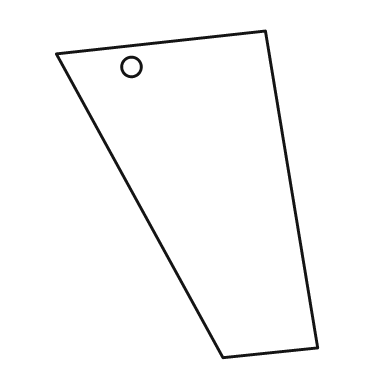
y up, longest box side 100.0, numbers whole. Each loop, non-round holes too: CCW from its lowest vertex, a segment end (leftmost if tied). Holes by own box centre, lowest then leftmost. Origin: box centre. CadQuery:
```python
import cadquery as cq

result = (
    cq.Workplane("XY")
    .moveTo(11.0, -50.0)
    .lineTo(40.0, -47.0)
    .lineTo(24.0, 50.0)
    .lineTo(-40.0, 43.0)
    .close()
    .moveTo(-17.0, 39.0)
    .circle(3.0)
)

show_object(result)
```